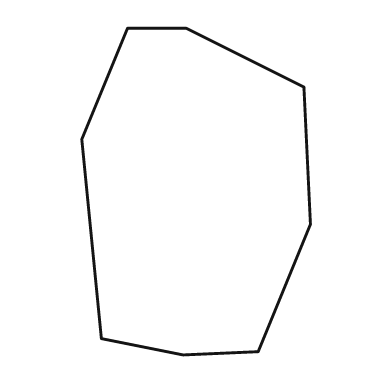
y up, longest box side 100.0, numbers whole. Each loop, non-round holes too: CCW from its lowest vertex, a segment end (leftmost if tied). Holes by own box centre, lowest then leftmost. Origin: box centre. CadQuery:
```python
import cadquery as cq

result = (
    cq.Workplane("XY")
    .moveTo(-4.0, -50.0)
    .lineTo(19.0, -49.0)
    .lineTo(35.0, -10.0)
    .lineTo(33.0, 32.0)
    .lineTo(-3.0, 50.0)
    .lineTo(-21.0, 50.0)
    .lineTo(-35.0, 16.0)
    .lineTo(-29.0, -45.0)
    .close()
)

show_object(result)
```